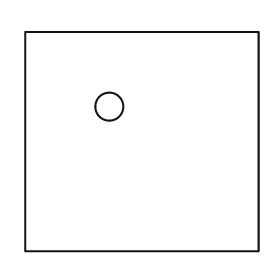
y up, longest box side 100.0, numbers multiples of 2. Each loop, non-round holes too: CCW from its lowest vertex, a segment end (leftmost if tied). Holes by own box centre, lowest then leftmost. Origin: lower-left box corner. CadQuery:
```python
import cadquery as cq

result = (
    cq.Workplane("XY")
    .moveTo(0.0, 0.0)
    .lineTo(100.0, 0.0)
    .lineTo(100.0, 94.0)
    .lineTo(0.0, 94.0)
    .close()
    .moveTo(36.0, 62.0)
    .circle(6.0)
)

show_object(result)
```